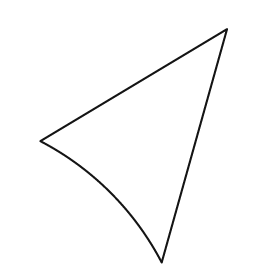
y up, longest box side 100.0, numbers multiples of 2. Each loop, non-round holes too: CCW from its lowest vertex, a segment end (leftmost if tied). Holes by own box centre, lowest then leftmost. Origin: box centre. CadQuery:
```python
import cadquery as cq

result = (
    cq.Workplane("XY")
    .moveTo(12.0, -50.0)
    .lineTo(40.0, 50.0)
    .lineTo(-40.0, 2.0)
    .threePointArc((-10.0, -20.0), (12.0, -50.0))
    .close()
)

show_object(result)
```